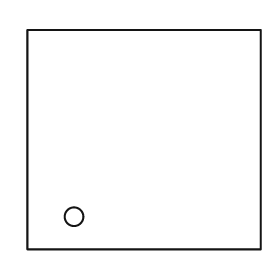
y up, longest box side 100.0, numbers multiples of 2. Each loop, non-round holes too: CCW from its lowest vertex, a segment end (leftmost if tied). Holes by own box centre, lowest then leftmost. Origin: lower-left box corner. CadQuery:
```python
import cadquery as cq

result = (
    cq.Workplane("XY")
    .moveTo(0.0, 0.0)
    .lineTo(100.0, 0.0)
    .lineTo(100.0, 94.0)
    .lineTo(0.0, 94.0)
    .close()
    .moveTo(20.0, 14.0)
    .circle(4.0)
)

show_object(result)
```